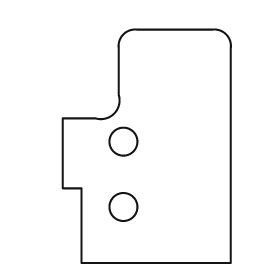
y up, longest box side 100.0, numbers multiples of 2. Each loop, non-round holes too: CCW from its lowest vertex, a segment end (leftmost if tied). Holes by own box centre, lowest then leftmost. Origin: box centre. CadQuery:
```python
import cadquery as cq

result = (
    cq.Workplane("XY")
    .moveTo(-28.0, -50.0)
    .lineTo(36.0, -50.0)
    .lineTo(36.0, 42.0)
    .threePointArc((34.0, 48.0), (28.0, 50.0))
    .lineTo(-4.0, 50.0)
    .threePointArc((-10.0, 48.0), (-12.0, 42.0))
    .lineTo(-12.0, 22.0)
    .threePointArc((-14.0, 14.0), (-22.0, 12.0))
    .lineTo(-36.0, 12.0)
    .lineTo(-36.0, -18.0)
    .lineTo(-28.0, -18.0)
    .close()
    .moveTo(-10.0, -26.0)
    .circle(6.0)
    .moveTo(-10.0, 2.0)
    .circle(6.0)
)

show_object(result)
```